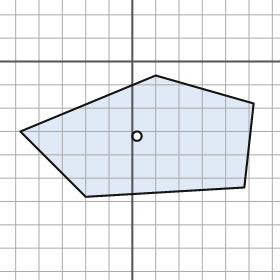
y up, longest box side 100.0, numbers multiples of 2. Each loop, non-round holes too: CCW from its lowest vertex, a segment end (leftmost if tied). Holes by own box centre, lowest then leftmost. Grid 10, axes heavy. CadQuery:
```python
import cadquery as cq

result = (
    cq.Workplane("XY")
    .moveTo(-20.0, -58.0)
    .lineTo(48.0, -54.0)
    .lineTo(52.0, -18.0)
    .lineTo(10.0, -6.0)
    .lineTo(-48.0, -30.0)
    .close()
    .moveTo(2.0, -32.0)
    .circle(2.0)
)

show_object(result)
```